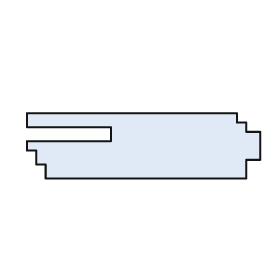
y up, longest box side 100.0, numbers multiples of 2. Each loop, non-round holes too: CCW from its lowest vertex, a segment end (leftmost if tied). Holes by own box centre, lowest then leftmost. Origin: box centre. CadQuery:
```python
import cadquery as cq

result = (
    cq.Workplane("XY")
    .moveTo(-42.0, -14.0)
    .lineTo(44.0, -14.0)
    .lineTo(44.0, -6.0)
    .lineTo(50.0, -6.0)
    .lineTo(50.0, 6.0)
    .lineTo(44.0, 6.0)
    .lineTo(44.0, 10.0)
    .lineTo(40.0, 10.0)
    .lineTo(40.0, 14.0)
    .lineTo(-50.0, 14.0)
    .lineTo(-50.0, 8.0)
    .lineTo(-14.0, 8.0)
    .lineTo(-14.0, 2.0)
    .lineTo(-50.0, 2.0)
    .lineTo(-50.0, -2.0)
    .lineTo(-46.0, -2.0)
    .lineTo(-46.0, -8.0)
    .lineTo(-42.0, -8.0)
    .close()
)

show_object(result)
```